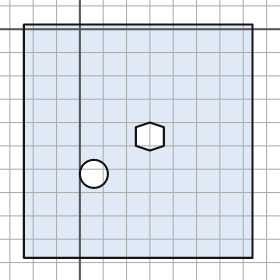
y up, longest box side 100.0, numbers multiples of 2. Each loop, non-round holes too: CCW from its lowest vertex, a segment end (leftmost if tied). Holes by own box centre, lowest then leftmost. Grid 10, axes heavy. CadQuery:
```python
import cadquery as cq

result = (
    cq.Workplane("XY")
    .moveTo(-24.0, -98.0)
    .lineTo(74.0, -98.0)
    .lineTo(74.0, 2.0)
    .lineTo(-24.0, 2.0)
    .close()
    .moveTo(6.0, -62.0)
    .circle(6.0)
    .moveTo(30.0, -52.0)
    .lineTo(36.0, -50.0)
    .lineTo(36.0, -42.0)
    .lineTo(30.0, -40.0)
    .lineTo(24.0, -42.0)
    .lineTo(24.0, -50.0)
    .close()
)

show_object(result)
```